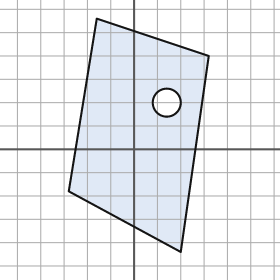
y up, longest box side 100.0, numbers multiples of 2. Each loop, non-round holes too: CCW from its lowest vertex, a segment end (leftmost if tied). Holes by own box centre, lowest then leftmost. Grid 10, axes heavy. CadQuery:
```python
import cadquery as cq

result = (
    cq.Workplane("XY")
    .moveTo(20.0, -44.0)
    .lineTo(32.0, 40.0)
    .lineTo(-16.0, 56.0)
    .lineTo(-28.0, -18.0)
    .close()
    .moveTo(14.0, 20.0)
    .circle(6.0)
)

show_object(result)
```